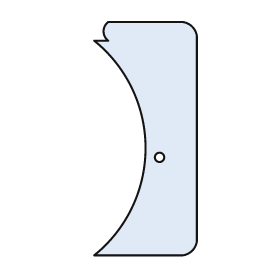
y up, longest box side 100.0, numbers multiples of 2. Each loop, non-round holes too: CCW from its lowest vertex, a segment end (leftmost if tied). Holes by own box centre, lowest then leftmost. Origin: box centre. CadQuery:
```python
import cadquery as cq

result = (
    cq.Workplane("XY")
    .moveTo(-22.0, -50.0)
    .lineTo(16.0, -50.0)
    .threePointArc((20.0, -48.0), (22.0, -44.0))
    .lineTo(22.0, 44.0)
    .threePointArc((20.0, 48.0), (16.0, 50.0))
    .lineTo(-16.0, 50.0)
    .threePointArc((-18.0, 46.0), (-16.0, 42.0))
    .lineTo(-22.0, 42.0)
    .threePointArc((0.0, -4.0), (-22.0, -50.0))
    .close()
    .moveTo(6.0, -8.0)
    .circle(2.0)
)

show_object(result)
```